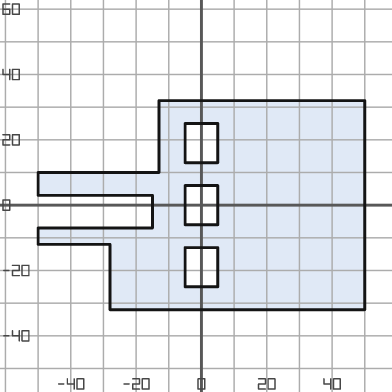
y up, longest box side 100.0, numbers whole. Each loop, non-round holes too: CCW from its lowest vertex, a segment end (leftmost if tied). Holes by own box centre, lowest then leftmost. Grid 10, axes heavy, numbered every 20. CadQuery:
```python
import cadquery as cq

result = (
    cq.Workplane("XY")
    .moveTo(-28.0, -32.0)
    .lineTo(50.0, -32.0)
    .lineTo(50.0, 32.0)
    .lineTo(-13.0, 32.0)
    .lineTo(-13.0, 10.0)
    .lineTo(-50.0, 10.0)
    .lineTo(-50.0, 3.0)
    .lineTo(-15.0, 3.0)
    .lineTo(-15.0, -7.0)
    .lineTo(-50.0, -7.0)
    .lineTo(-50.0, -12.0)
    .lineTo(-28.0, -12.0)
    .close()
    .moveTo(-5.0, -25.0)
    .lineTo(5.0, -25.0)
    .lineTo(5.0, -13.0)
    .lineTo(-5.0, -13.0)
    .close()
    .moveTo(-5.0, -6.0)
    .lineTo(5.0, -6.0)
    .lineTo(5.0, 6.0)
    .lineTo(-5.0, 6.0)
    .close()
    .moveTo(-5.0, 13.0)
    .lineTo(5.0, 13.0)
    .lineTo(5.0, 25.0)
    .lineTo(-5.0, 25.0)
    .close()
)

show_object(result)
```